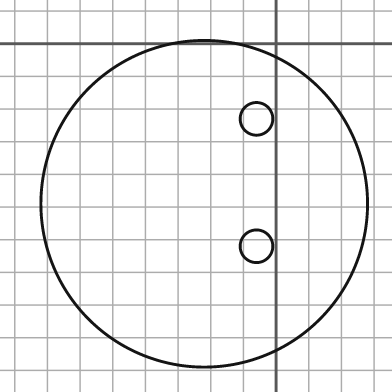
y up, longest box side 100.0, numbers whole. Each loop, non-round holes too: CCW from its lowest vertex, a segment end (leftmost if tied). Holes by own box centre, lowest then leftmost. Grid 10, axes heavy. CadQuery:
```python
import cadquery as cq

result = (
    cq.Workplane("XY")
    .moveTo(-22.0, -49.0)
    .circle(50.0)
    .moveTo(-6.0, -62.0)
    .circle(5.0)
    .moveTo(-6.0, -23.0)
    .circle(5.0)
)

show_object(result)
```